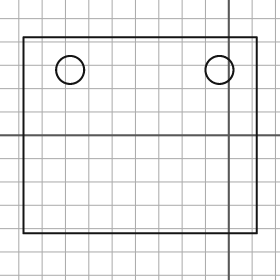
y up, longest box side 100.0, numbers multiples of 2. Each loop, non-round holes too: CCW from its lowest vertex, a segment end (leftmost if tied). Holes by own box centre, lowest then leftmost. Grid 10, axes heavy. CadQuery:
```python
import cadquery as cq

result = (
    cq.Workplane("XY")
    .moveTo(-88.0, -42.0)
    .lineTo(12.0, -42.0)
    .lineTo(12.0, 42.0)
    .lineTo(-88.0, 42.0)
    .close()
    .moveTo(-68.0, 28.0)
    .circle(6.0)
    .moveTo(-4.0, 28.0)
    .circle(6.0)
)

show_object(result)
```